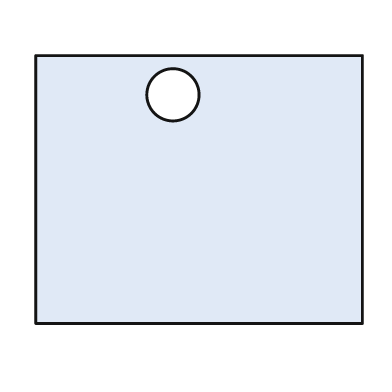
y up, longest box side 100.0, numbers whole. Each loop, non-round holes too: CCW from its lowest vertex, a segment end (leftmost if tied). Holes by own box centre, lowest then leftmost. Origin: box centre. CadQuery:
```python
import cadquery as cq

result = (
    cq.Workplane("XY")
    .moveTo(-50.0, -41.0)
    .lineTo(50.0, -41.0)
    .lineTo(50.0, 41.0)
    .lineTo(-50.0, 41.0)
    .close()
    .moveTo(-8.0, 29.0)
    .circle(8.0)
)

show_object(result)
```